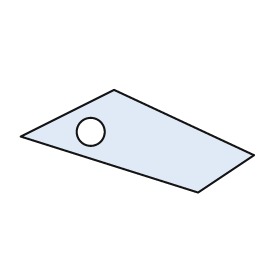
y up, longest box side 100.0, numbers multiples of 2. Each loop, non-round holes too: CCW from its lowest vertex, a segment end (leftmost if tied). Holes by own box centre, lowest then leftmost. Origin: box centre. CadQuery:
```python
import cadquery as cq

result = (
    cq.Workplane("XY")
    .moveTo(26.0, -22.0)
    .lineTo(50.0, -6.0)
    .lineTo(-10.0, 22.0)
    .lineTo(-50.0, 2.0)
    .close()
    .moveTo(-20.0, 4.0)
    .circle(6.0)
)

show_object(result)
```